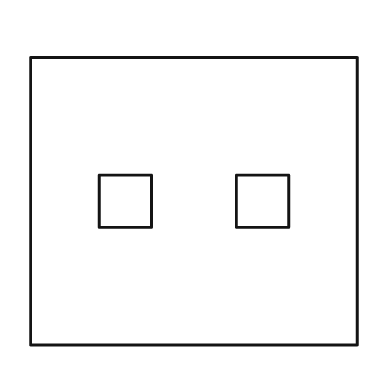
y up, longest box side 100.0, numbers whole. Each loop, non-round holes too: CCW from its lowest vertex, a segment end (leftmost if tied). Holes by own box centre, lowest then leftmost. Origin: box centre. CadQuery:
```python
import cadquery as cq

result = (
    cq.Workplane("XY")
    .moveTo(-50.0, -44.0)
    .lineTo(50.0, -44.0)
    .lineTo(50.0, 44.0)
    .lineTo(-50.0, 44.0)
    .close()
    .moveTo(-29.0, -8.0)
    .lineTo(-13.0, -8.0)
    .lineTo(-13.0, 8.0)
    .lineTo(-29.0, 8.0)
    .close()
    .moveTo(13.0, -8.0)
    .lineTo(29.0, -8.0)
    .lineTo(29.0, 8.0)
    .lineTo(13.0, 8.0)
    .close()
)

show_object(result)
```